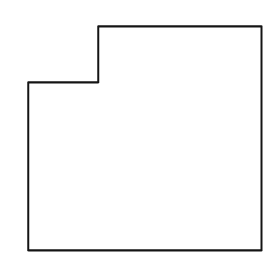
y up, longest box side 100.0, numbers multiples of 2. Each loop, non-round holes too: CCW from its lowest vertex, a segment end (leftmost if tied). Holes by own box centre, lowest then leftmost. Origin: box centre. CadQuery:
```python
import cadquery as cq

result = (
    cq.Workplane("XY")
    .moveTo(-50.0, -48.0)
    .lineTo(50.0, -48.0)
    .lineTo(50.0, 48.0)
    .lineTo(-20.0, 48.0)
    .lineTo(-20.0, 24.0)
    .lineTo(-50.0, 24.0)
    .close()
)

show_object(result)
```